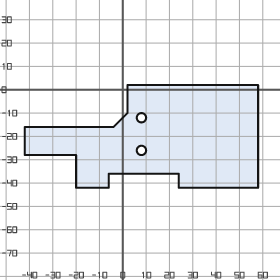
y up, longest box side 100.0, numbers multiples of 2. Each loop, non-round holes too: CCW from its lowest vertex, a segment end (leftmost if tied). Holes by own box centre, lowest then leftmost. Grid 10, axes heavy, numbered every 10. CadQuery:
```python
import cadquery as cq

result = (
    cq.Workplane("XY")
    .moveTo(-20.0, -42.0)
    .lineTo(-6.0, -42.0)
    .lineTo(-6.0, -36.0)
    .lineTo(24.0, -36.0)
    .lineTo(24.0, -42.0)
    .lineTo(58.0, -42.0)
    .lineTo(58.0, 2.0)
    .lineTo(2.0, 2.0)
    .lineTo(2.0, -10.0)
    .lineTo(-4.0, -16.0)
    .lineTo(-42.0, -16.0)
    .lineTo(-42.0, -28.0)
    .lineTo(-20.0, -28.0)
    .close()
    .moveTo(8.0, -26.0)
    .circle(2.0)
    .moveTo(8.0, -12.0)
    .circle(2.0)
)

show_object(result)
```